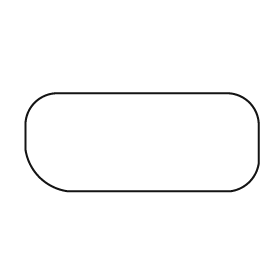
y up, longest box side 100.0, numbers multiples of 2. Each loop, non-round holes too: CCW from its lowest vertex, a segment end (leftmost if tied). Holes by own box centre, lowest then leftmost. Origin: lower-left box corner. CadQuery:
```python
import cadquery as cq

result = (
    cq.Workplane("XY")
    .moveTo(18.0, 0.0)
    .lineTo(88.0, 0.0)
    .threePointArc((96.0, 4.0), (100.0, 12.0))
    .lineTo(100.0, 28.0)
    .threePointArc((96.0, 38.0), (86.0, 42.0))
    .lineTo(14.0, 42.0)
    .threePointArc((4.0, 38.0), (0.0, 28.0))
    .lineTo(0.0, 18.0)
    .threePointArc((6.0, 6.0), (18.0, 0.0))
    .close()
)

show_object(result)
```